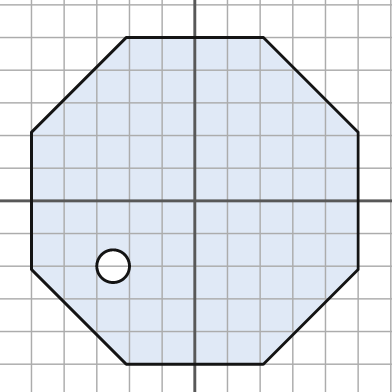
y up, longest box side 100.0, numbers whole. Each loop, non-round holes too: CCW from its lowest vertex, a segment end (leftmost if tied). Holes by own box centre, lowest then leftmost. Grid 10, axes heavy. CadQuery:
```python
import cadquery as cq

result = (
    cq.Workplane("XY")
    .moveTo(-21.0, -50.0)
    .lineTo(21.0, -50.0)
    .lineTo(50.0, -21.0)
    .lineTo(50.0, 21.0)
    .lineTo(21.0, 50.0)
    .lineTo(-21.0, 50.0)
    .lineTo(-50.0, 21.0)
    .lineTo(-50.0, -21.0)
    .close()
    .moveTo(-25.0, -20.0)
    .circle(5.0)
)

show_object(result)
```